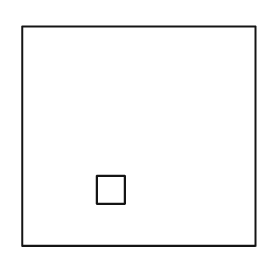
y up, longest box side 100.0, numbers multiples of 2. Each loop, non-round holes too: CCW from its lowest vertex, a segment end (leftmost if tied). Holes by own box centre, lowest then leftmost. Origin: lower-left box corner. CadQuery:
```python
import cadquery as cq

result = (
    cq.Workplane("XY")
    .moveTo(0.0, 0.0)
    .lineTo(100.0, 0.0)
    .lineTo(100.0, 94.0)
    .lineTo(0.0, 94.0)
    .close()
    .moveTo(32.0, 18.0)
    .lineTo(44.0, 18.0)
    .lineTo(44.0, 30.0)
    .lineTo(32.0, 30.0)
    .close()
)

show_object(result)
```